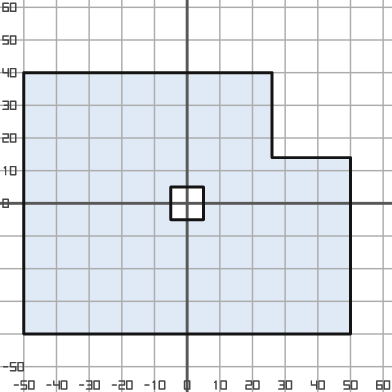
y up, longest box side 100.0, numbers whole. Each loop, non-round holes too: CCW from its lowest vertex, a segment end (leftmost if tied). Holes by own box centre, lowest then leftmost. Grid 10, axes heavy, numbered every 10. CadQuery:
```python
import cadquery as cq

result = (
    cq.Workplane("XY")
    .moveTo(-50.0, -40.0)
    .lineTo(50.0, -40.0)
    .lineTo(50.0, 14.0)
    .lineTo(26.0, 14.0)
    .lineTo(26.0, 40.0)
    .lineTo(-50.0, 40.0)
    .close()
    .moveTo(-5.0, -5.0)
    .lineTo(5.0, -5.0)
    .lineTo(5.0, 5.0)
    .lineTo(-5.0, 5.0)
    .close()
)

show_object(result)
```